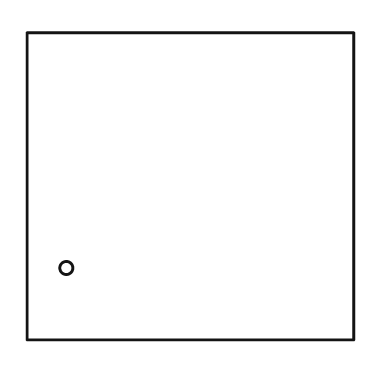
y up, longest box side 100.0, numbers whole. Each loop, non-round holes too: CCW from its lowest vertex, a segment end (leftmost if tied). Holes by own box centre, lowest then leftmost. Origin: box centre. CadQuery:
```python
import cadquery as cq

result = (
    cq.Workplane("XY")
    .moveTo(-50.0, -47.0)
    .lineTo(50.0, -47.0)
    .lineTo(50.0, 47.0)
    .lineTo(-50.0, 47.0)
    .close()
    .moveTo(-38.0, -25.0)
    .circle(2.0)
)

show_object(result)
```